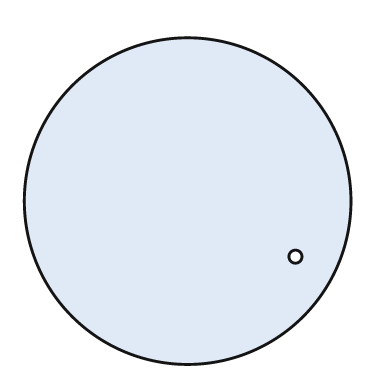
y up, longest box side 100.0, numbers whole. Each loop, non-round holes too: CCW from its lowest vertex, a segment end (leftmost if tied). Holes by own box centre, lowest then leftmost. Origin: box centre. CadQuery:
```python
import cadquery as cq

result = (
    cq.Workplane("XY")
    .moveTo(0.0, 0.0)
    .circle(50.0)
    .moveTo(33.0, -17.0)
    .circle(2.0)
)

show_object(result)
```